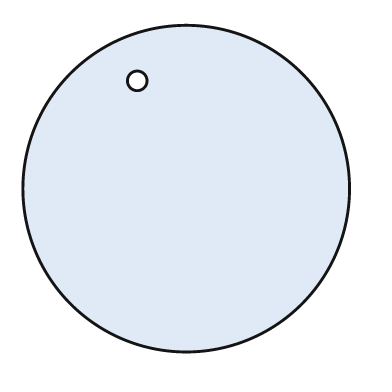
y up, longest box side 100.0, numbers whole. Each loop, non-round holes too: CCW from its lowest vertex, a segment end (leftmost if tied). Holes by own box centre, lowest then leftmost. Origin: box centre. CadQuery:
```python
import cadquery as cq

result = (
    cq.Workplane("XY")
    .moveTo(0.0, 0.0)
    .circle(50.0)
    .moveTo(-15.0, 33.0)
    .circle(3.0)
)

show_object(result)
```